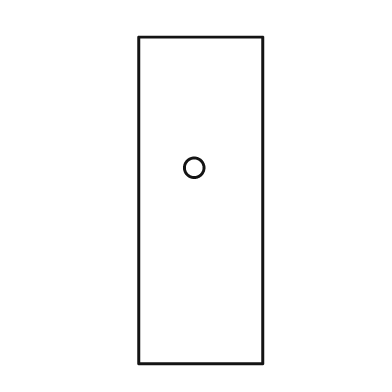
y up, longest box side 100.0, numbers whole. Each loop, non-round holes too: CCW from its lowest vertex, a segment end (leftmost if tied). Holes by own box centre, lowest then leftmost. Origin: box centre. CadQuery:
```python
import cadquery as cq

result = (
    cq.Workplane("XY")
    .moveTo(-19.0, -50.0)
    .lineTo(19.0, -50.0)
    .lineTo(19.0, 50.0)
    .lineTo(-19.0, 50.0)
    .close()
    .moveTo(-2.0, 10.0)
    .circle(3.0)
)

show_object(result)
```